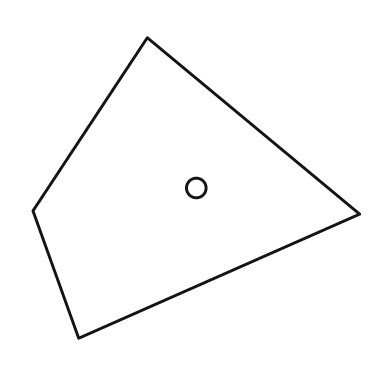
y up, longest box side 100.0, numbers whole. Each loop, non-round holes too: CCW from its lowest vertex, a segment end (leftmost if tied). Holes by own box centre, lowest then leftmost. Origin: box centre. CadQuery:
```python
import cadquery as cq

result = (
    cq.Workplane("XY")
    .moveTo(-36.0, -46.0)
    .lineTo(50.0, -8.0)
    .lineTo(-15.0, 46.0)
    .lineTo(-50.0, -7.0)
    .close()
    .moveTo(0.0, 0.0)
    .circle(3.0)
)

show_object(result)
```